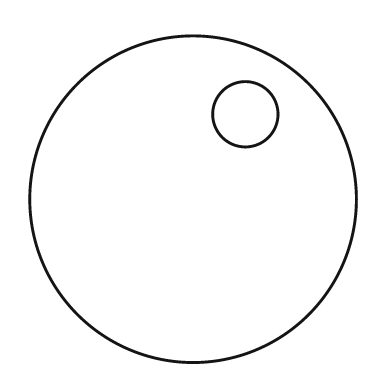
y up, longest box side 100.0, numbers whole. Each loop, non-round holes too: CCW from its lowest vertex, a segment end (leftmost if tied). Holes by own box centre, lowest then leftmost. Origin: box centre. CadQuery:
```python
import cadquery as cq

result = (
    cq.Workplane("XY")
    .moveTo(0.0, 0.0)
    .circle(50.0)
    .moveTo(16.0, 26.0)
    .circle(10.0)
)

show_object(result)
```